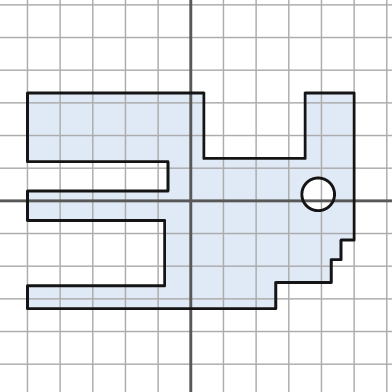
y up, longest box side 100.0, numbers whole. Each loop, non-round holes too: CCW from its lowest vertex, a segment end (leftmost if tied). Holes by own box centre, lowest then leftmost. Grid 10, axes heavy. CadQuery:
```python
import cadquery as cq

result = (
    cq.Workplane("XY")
    .moveTo(-50.0, -33.0)
    .lineTo(26.0, -33.0)
    .lineTo(26.0, -25.0)
    .lineTo(43.0, -25.0)
    .lineTo(43.0, -18.0)
    .lineTo(46.0, -18.0)
    .lineTo(46.0, -12.0)
    .lineTo(50.0, -12.0)
    .lineTo(50.0, 33.0)
    .lineTo(35.0, 33.0)
    .lineTo(35.0, 13.0)
    .lineTo(4.0, 13.0)
    .lineTo(4.0, 33.0)
    .lineTo(-50.0, 33.0)
    .lineTo(-50.0, 12.0)
    .lineTo(-7.0, 12.0)
    .lineTo(-7.0, 3.0)
    .lineTo(-50.0, 3.0)
    .lineTo(-50.0, -6.0)
    .lineTo(-8.0, -6.0)
    .lineTo(-8.0, -26.0)
    .lineTo(-50.0, -26.0)
    .close()
    .moveTo(39.0, 2.0)
    .circle(5.0)
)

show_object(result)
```